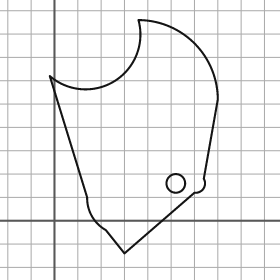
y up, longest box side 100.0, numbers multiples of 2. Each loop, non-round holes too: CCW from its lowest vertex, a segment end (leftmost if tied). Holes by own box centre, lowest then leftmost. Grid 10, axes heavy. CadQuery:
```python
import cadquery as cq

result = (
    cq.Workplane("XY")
    .moveTo(30.0, -14.0)
    .lineTo(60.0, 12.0)
    .threePointArc((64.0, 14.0), (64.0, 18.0))
    .lineTo(70.0, 52.0)
    .threePointArc((60.0, 76.0), (36.0, 86.0))
    .threePointArc((26.0, 60.0), (-2.0, 62.0))
    .lineTo(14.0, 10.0)
    .threePointArc((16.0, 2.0), (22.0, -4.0))
    .close()
    .moveTo(52.0, 16.0)
    .circle(4.0)
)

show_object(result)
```